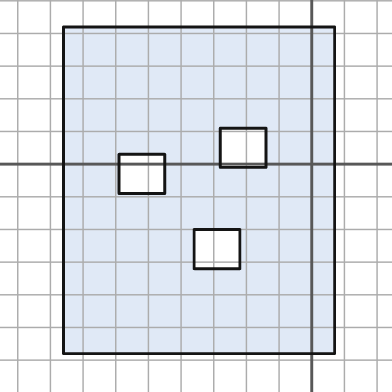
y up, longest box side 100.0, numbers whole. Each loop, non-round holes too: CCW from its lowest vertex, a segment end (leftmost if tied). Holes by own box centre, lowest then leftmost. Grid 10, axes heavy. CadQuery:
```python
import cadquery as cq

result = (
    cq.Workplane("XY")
    .moveTo(-76.0, -58.0)
    .lineTo(7.0, -58.0)
    .lineTo(7.0, 42.0)
    .lineTo(-76.0, 42.0)
    .close()
    .moveTo(-36.0, -32.0)
    .lineTo(-22.0, -32.0)
    .lineTo(-22.0, -20.0)
    .lineTo(-36.0, -20.0)
    .close()
    .moveTo(-59.0, -9.0)
    .lineTo(-45.0, -9.0)
    .lineTo(-45.0, 3.0)
    .lineTo(-59.0, 3.0)
    .close()
    .moveTo(-28.0, -1.0)
    .lineTo(-14.0, -1.0)
    .lineTo(-14.0, 11.0)
    .lineTo(-28.0, 11.0)
    .close()
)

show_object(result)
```